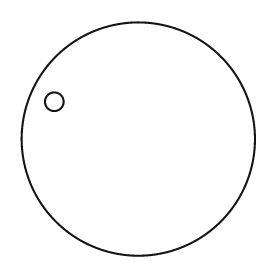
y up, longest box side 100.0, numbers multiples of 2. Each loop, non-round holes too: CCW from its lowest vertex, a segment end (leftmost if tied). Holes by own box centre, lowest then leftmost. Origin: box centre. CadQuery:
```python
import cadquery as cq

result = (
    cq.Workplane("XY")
    .moveTo(0.0, 0.0)
    .circle(50.0)
    .moveTo(-36.0, 16.0)
    .circle(4.0)
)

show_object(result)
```